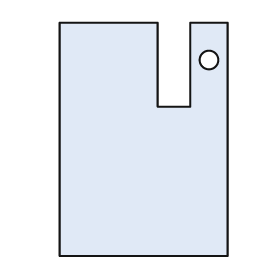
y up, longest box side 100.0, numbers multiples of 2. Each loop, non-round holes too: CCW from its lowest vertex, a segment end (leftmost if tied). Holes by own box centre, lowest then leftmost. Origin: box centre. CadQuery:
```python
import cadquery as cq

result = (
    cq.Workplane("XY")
    .moveTo(-36.0, -50.0)
    .lineTo(36.0, -50.0)
    .lineTo(36.0, 50.0)
    .lineTo(20.0, 50.0)
    .lineTo(20.0, 14.0)
    .lineTo(6.0, 14.0)
    .lineTo(6.0, 50.0)
    .lineTo(-36.0, 50.0)
    .close()
    .moveTo(28.0, 34.0)
    .circle(4.0)
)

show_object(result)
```